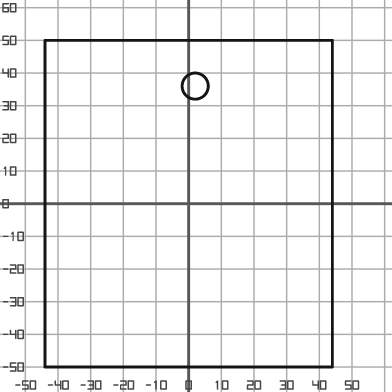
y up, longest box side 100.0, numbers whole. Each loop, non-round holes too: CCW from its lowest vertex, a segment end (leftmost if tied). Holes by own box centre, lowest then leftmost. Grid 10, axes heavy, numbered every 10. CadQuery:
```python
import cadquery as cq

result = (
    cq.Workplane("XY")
    .moveTo(-44.0, -50.0)
    .lineTo(44.0, -50.0)
    .lineTo(44.0, 50.0)
    .lineTo(-44.0, 50.0)
    .close()
    .moveTo(2.0, 36.0)
    .circle(4.0)
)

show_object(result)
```